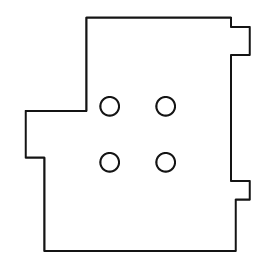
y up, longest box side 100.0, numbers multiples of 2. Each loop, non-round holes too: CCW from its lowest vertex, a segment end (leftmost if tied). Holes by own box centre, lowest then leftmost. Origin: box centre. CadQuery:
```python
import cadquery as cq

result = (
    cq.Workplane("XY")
    .moveTo(-40.0, -50.0)
    .lineTo(42.0, -50.0)
    .lineTo(42.0, -28.0)
    .lineTo(48.0, -28.0)
    .lineTo(48.0, -20.0)
    .lineTo(40.0, -20.0)
    .lineTo(40.0, 34.0)
    .lineTo(48.0, 34.0)
    .lineTo(48.0, 46.0)
    .lineTo(40.0, 46.0)
    .lineTo(40.0, 50.0)
    .lineTo(-22.0, 50.0)
    .lineTo(-22.0, 10.0)
    .lineTo(-48.0, 10.0)
    .lineTo(-48.0, -10.0)
    .lineTo(-40.0, -10.0)
    .close()
    .moveTo(-12.0, -12.0)
    .circle(4.0)
    .moveTo(12.0, -12.0)
    .circle(4.0)
    .moveTo(-12.0, 12.0)
    .circle(4.0)
    .moveTo(12.0, 12.0)
    .circle(4.0)
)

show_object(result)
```